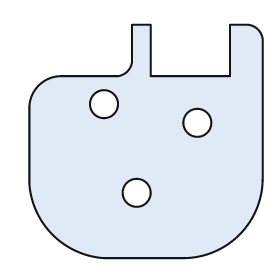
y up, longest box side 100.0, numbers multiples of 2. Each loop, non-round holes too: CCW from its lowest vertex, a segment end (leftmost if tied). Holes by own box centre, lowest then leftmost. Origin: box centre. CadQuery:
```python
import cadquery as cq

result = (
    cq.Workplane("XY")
    .moveTo(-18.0, -50.0)
    .lineTo(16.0, -50.0)
    .threePointArc((40.0, -40.0), (50.0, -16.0))
    .lineTo(50.0, 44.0)
    .threePointArc((48.0, 48.0), (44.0, 50.0))
    .lineTo(36.0, 50.0)
    .lineTo(36.0, 28.0)
    .lineTo(2.0, 28.0)
    .lineTo(2.0, 50.0)
    .lineTo(-6.0, 50.0)
    .lineTo(-6.0, 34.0)
    .threePointArc((-8.0, 30.0), (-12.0, 28.0))
    .lineTo(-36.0, 28.0)
    .threePointArc((-46.0, 24.0), (-50.0, 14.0))
    .lineTo(-50.0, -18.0)
    .threePointArc((-40.0, -40.0), (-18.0, -50.0))
    .close()
    .moveTo(-4.0, -22.0)
    .circle(6.0)
    .moveTo(22.0, 8.0)
    .circle(6.0)
    .moveTo(-18.0, 16.0)
    .circle(6.0)
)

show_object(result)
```